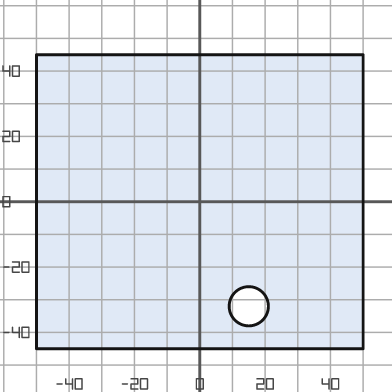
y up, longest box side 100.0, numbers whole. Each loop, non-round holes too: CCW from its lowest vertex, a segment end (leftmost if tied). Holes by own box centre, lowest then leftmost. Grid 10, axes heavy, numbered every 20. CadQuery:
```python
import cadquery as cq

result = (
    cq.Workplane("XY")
    .moveTo(-50.0, -45.0)
    .lineTo(50.0, -45.0)
    .lineTo(50.0, 45.0)
    .lineTo(-50.0, 45.0)
    .close()
    .moveTo(15.0, -32.0)
    .circle(6.0)
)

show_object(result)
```